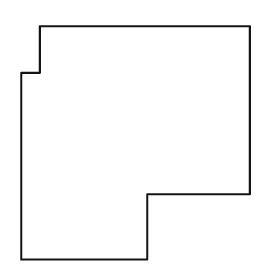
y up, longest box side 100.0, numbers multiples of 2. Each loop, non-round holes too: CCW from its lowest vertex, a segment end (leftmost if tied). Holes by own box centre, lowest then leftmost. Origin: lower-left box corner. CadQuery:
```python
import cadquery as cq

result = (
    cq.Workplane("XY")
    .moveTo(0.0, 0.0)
    .lineTo(54.0, 0.0)
    .lineTo(54.0, 28.0)
    .lineTo(98.0, 28.0)
    .lineTo(98.0, 100.0)
    .lineTo(8.0, 100.0)
    .lineTo(8.0, 80.0)
    .lineTo(0.0, 80.0)
    .close()
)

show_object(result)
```